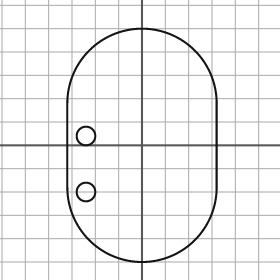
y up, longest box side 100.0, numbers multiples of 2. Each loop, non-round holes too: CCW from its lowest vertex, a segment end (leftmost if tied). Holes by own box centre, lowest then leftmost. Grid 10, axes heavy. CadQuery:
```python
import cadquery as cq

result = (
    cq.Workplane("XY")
    .moveTo(-32.0, -18.0)
    .threePointArc((0.0, -50.0), (32.0, -18.0))
    .lineTo(32.0, 18.0)
    .threePointArc((0.0, 50.0), (-32.0, 18.0))
    .close()
    .moveTo(-24.0, -20.0)
    .circle(4.0)
    .moveTo(-24.0, 4.0)
    .circle(4.0)
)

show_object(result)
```